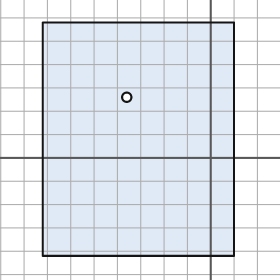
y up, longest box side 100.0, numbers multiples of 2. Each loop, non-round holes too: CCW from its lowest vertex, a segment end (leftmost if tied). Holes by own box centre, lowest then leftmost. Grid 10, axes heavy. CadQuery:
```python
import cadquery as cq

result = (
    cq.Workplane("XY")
    .moveTo(-72.0, -42.0)
    .lineTo(10.0, -42.0)
    .lineTo(10.0, 58.0)
    .lineTo(-72.0, 58.0)
    .close()
    .moveTo(-36.0, 26.0)
    .circle(2.0)
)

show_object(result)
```